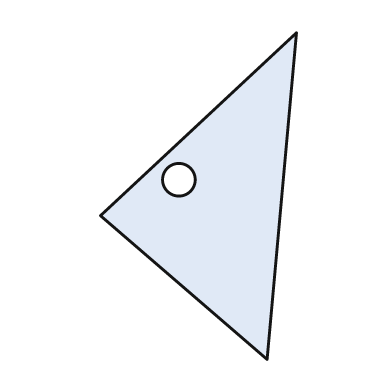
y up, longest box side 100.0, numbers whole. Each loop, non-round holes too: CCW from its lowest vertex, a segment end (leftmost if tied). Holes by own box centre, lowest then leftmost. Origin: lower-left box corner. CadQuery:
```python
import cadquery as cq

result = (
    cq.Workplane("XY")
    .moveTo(51.0, 0.0)
    .lineTo(60.0, 100.0)
    .lineTo(0.0, 44.0)
    .close()
    .moveTo(24.0, 55.0)
    .circle(5.0)
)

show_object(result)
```